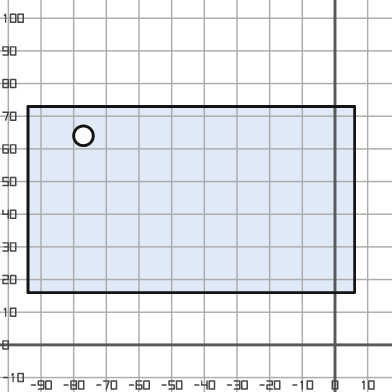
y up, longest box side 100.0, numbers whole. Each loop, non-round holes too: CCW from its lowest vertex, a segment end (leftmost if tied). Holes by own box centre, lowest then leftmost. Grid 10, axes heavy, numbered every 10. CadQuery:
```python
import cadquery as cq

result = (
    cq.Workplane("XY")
    .moveTo(-94.0, 16.0)
    .lineTo(6.0, 16.0)
    .lineTo(6.0, 73.0)
    .lineTo(-94.0, 73.0)
    .close()
    .moveTo(-77.0, 64.0)
    .circle(3.0)
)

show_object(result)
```